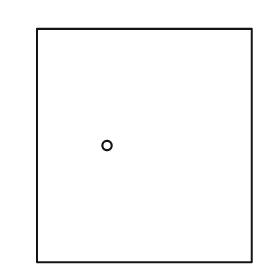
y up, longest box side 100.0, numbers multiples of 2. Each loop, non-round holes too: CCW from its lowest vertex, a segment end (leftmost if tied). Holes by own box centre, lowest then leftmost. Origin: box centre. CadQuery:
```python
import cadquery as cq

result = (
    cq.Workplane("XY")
    .moveTo(-46.0, -50.0)
    .lineTo(46.0, -50.0)
    .lineTo(46.0, 50.0)
    .lineTo(-46.0, 50.0)
    .close()
    .moveTo(-16.0, 0.0)
    .circle(2.0)
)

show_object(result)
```